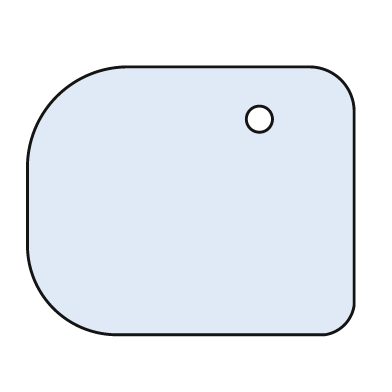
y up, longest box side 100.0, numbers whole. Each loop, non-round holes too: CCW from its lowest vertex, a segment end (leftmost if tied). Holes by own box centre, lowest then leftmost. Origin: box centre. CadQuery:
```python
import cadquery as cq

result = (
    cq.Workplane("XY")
    .moveTo(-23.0, -41.0)
    .lineTo(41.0, -41.0)
    .threePointArc((47.0, -38.0), (50.0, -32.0))
    .lineTo(50.0, 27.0)
    .threePointArc((46.0, 37.0), (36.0, 41.0))
    .lineTo(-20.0, 41.0)
    .threePointArc((-41.0, 32.0), (-50.0, 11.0))
    .lineTo(-50.0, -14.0)
    .threePointArc((-42.0, -33.0), (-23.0, -41.0))
    .close()
    .moveTo(21.0, 25.0)
    .circle(4.0)
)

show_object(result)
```